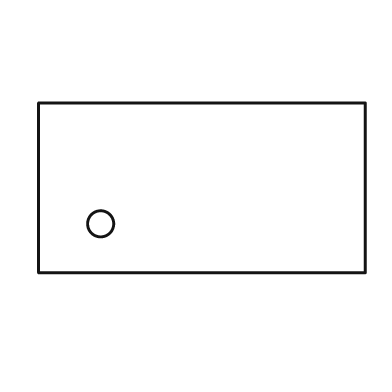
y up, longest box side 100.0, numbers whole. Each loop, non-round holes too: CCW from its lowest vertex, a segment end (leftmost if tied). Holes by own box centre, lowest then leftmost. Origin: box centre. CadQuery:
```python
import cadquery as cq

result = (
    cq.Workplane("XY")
    .moveTo(-50.0, -26.0)
    .lineTo(50.0, -26.0)
    .lineTo(50.0, 26.0)
    .lineTo(-50.0, 26.0)
    .close()
    .moveTo(-31.0, -11.0)
    .circle(4.0)
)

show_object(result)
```